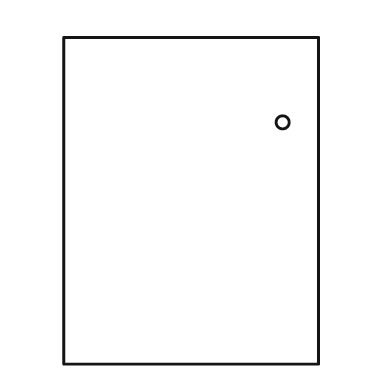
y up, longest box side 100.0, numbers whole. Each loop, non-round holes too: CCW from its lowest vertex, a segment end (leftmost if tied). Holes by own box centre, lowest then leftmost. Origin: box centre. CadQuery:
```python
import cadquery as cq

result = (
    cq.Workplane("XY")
    .moveTo(-39.0, -50.0)
    .lineTo(39.0, -50.0)
    .lineTo(39.0, 50.0)
    .lineTo(-39.0, 50.0)
    .close()
    .moveTo(28.0, 24.0)
    .circle(2.0)
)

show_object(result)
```